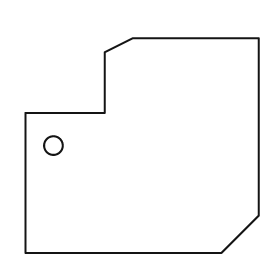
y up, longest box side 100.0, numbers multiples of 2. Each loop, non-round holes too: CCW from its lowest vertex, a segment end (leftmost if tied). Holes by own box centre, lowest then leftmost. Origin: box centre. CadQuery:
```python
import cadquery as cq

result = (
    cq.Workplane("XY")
    .moveTo(-50.0, -46.0)
    .lineTo(34.0, -46.0)
    .lineTo(50.0, -30.0)
    .lineTo(50.0, 46.0)
    .lineTo(-4.0, 46.0)
    .lineTo(-16.0, 40.0)
    .lineTo(-16.0, 14.0)
    .lineTo(-50.0, 14.0)
    .close()
    .moveTo(-38.0, 0.0)
    .circle(4.0)
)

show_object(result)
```